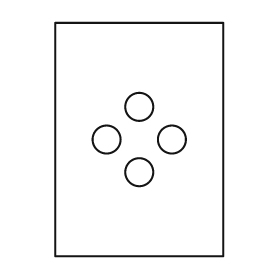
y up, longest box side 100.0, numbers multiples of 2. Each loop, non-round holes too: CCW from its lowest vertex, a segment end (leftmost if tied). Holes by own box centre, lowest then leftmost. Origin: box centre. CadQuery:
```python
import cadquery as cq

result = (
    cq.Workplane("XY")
    .moveTo(-36.0, -50.0)
    .lineTo(36.0, -50.0)
    .lineTo(36.0, 50.0)
    .lineTo(-36.0, 50.0)
    .close()
    .moveTo(0.0, -14.0)
    .circle(6.0)
    .moveTo(-14.0, 0.0)
    .circle(6.0)
    .moveTo(14.0, 0.0)
    .circle(6.0)
    .moveTo(0.0, 14.0)
    .circle(6.0)
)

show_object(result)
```